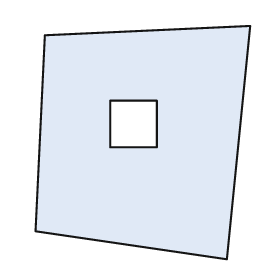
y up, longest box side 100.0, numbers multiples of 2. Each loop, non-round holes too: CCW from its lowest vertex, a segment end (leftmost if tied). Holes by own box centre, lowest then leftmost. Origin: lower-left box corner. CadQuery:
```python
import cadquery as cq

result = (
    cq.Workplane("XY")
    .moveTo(82.0, 0.0)
    .lineTo(92.0, 100.0)
    .lineTo(4.0, 96.0)
    .lineTo(0.0, 12.0)
    .close()
    .moveTo(32.0, 48.0)
    .lineTo(52.0, 48.0)
    .lineTo(52.0, 68.0)
    .lineTo(32.0, 68.0)
    .close()
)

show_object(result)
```